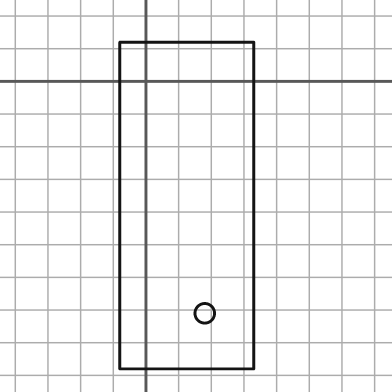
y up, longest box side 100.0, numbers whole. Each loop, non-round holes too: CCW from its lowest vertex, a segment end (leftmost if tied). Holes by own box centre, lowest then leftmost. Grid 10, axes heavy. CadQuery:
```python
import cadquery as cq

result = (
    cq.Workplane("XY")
    .moveTo(-8.0, -88.0)
    .lineTo(33.0, -88.0)
    .lineTo(33.0, 12.0)
    .lineTo(-8.0, 12.0)
    .close()
    .moveTo(18.0, -71.0)
    .circle(3.0)
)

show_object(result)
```